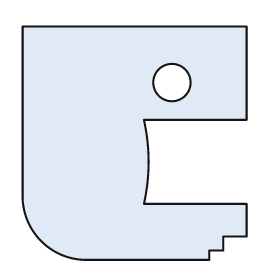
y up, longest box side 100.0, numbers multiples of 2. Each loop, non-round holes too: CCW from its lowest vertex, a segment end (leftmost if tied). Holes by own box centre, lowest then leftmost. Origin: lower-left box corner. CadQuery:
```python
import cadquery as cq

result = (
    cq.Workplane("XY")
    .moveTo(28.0, 0.0)
    .lineTo(80.0, 0.0)
    .lineTo(80.0, 4.0)
    .lineTo(86.0, 4.0)
    .lineTo(86.0, 10.0)
    .lineTo(96.0, 10.0)
    .lineTo(96.0, 24.0)
    .lineTo(52.0, 24.0)
    .threePointArc((54.0, 42.0), (52.0, 60.0))
    .lineTo(96.0, 60.0)
    .lineTo(96.0, 100.0)
    .lineTo(0.0, 100.0)
    .lineTo(0.0, 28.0)
    .threePointArc((8.0, 8.0), (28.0, 0.0))
    .close()
    .moveTo(64.0, 76.0)
    .circle(8.0)
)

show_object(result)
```